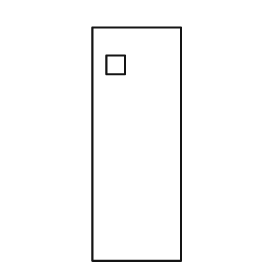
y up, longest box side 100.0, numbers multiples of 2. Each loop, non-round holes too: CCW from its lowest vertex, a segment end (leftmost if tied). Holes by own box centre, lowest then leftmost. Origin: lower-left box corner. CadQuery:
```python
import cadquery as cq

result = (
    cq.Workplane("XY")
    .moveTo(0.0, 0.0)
    .lineTo(38.0, 0.0)
    .lineTo(38.0, 100.0)
    .lineTo(0.0, 100.0)
    .close()
    .moveTo(6.0, 80.0)
    .lineTo(14.0, 80.0)
    .lineTo(14.0, 88.0)
    .lineTo(6.0, 88.0)
    .close()
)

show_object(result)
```